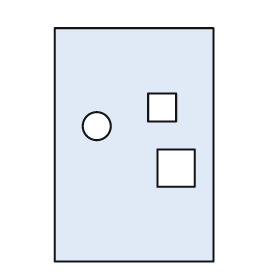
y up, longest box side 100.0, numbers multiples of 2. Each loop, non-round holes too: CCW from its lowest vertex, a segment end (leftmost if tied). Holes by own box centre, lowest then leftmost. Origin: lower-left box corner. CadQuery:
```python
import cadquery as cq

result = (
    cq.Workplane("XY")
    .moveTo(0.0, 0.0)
    .lineTo(68.0, 0.0)
    .lineTo(68.0, 100.0)
    .lineTo(0.0, 100.0)
    .close()
    .moveTo(44.0, 32.0)
    .lineTo(60.0, 32.0)
    .lineTo(60.0, 48.0)
    .lineTo(44.0, 48.0)
    .close()
    .moveTo(18.0, 58.0)
    .circle(6.0)
    .moveTo(40.0, 60.0)
    .lineTo(52.0, 60.0)
    .lineTo(52.0, 72.0)
    .lineTo(40.0, 72.0)
    .close()
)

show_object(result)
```